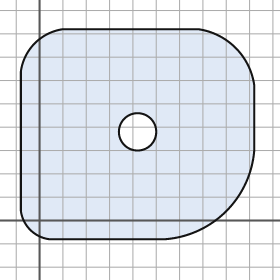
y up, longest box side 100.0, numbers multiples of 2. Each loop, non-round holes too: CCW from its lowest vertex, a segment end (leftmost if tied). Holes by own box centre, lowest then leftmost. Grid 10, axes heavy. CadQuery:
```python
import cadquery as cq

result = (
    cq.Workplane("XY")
    .moveTo(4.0, -8.0)
    .lineTo(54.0, -8.0)
    .threePointArc((80.0, 4.0), (92.0, 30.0))
    .lineTo(92.0, 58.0)
    .threePointArc((84.0, 74.0), (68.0, 82.0))
    .lineTo(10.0, 82.0)
    .threePointArc((-2.0, 76.0), (-8.0, 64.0))
    .lineTo(-8.0, 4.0)
    .threePointArc((-4.0, -4.0), (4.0, -8.0))
    .close()
    .moveTo(42.0, 38.0)
    .circle(8.0)
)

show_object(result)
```